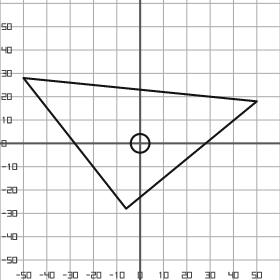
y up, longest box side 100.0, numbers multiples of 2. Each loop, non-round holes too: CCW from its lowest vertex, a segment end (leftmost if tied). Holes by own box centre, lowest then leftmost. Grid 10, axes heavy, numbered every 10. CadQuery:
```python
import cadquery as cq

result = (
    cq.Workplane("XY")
    .moveTo(-6.0, -28.0)
    .lineTo(50.0, 18.0)
    .lineTo(-50.0, 28.0)
    .close()
    .moveTo(0.0, 0.0)
    .circle(4.0)
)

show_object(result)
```